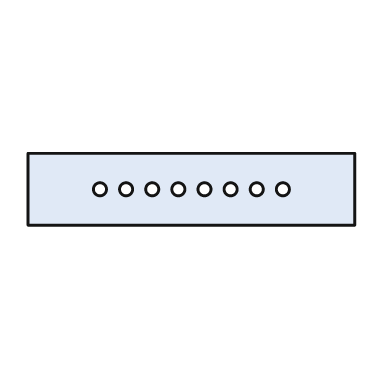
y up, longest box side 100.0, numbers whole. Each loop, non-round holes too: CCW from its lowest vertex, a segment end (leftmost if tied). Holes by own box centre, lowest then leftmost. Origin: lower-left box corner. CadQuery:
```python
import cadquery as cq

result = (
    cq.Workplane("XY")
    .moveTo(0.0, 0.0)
    .lineTo(100.0, 0.0)
    .lineTo(100.0, 22.0)
    .lineTo(0.0, 22.0)
    .close()
    .moveTo(22.0, 11.0)
    .circle(2.0)
    .moveTo(30.0, 11.0)
    .circle(2.0)
    .moveTo(38.0, 11.0)
    .circle(2.0)
    .moveTo(46.0, 11.0)
    .circle(2.0)
    .moveTo(54.0, 11.0)
    .circle(2.0)
    .moveTo(62.0, 11.0)
    .circle(2.0)
    .moveTo(70.0, 11.0)
    .circle(2.0)
    .moveTo(78.0, 11.0)
    .circle(2.0)
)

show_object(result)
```